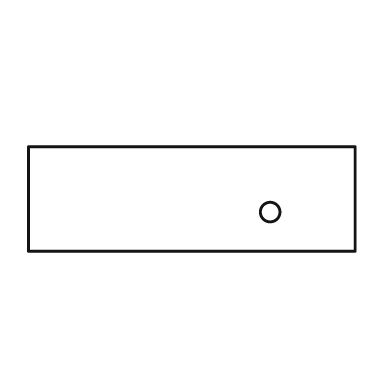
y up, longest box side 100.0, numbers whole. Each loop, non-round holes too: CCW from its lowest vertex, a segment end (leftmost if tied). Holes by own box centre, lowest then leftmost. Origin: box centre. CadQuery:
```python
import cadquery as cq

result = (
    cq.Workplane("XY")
    .moveTo(-50.0, -16.0)
    .lineTo(50.0, -16.0)
    .lineTo(50.0, 16.0)
    .lineTo(-50.0, 16.0)
    .close()
    .moveTo(24.0, -4.0)
    .circle(3.0)
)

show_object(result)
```